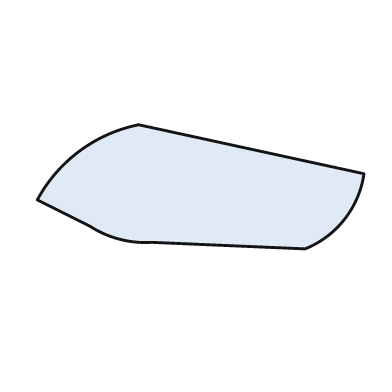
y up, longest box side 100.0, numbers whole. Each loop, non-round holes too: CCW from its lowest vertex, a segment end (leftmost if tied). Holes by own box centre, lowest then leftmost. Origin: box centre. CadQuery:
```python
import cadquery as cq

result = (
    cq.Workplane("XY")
    .moveTo(32.0, -19.0)
    .threePointArc((44.0, -10.0), (50.0, 4.0))
    .lineTo(-19.0, 19.0)
    .threePointArc((-37.0, 11.0), (-50.0, -4.0))
    .lineTo(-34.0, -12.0)
    .threePointArc((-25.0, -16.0), (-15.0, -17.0))
    .close()
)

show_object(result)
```